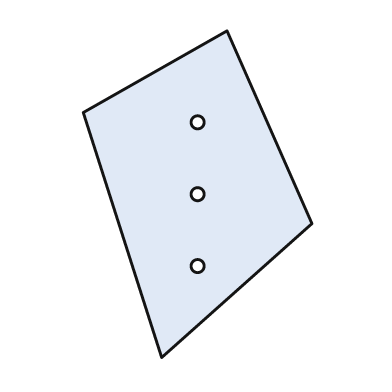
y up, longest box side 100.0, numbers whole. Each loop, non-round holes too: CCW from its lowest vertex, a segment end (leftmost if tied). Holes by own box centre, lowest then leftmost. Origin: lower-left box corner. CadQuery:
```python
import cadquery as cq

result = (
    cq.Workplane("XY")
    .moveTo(24.0, 0.0)
    .lineTo(70.0, 41.0)
    .lineTo(44.0, 100.0)
    .lineTo(0.0, 75.0)
    .close()
    .moveTo(35.0, 28.0)
    .circle(2.0)
    .moveTo(35.0, 50.0)
    .circle(2.0)
    .moveTo(35.0, 72.0)
    .circle(2.0)
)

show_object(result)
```